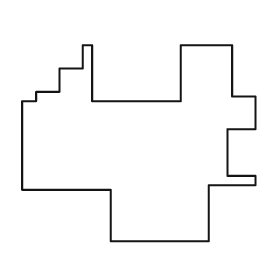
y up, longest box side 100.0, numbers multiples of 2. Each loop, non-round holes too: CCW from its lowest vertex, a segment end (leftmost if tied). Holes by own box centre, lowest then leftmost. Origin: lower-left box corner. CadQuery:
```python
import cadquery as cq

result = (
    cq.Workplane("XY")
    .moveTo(38.0, 0.0)
    .lineTo(80.0, 0.0)
    .lineTo(80.0, 24.0)
    .lineTo(100.0, 24.0)
    .lineTo(100.0, 28.0)
    .lineTo(88.0, 28.0)
    .lineTo(88.0, 48.0)
    .lineTo(100.0, 48.0)
    .lineTo(100.0, 62.0)
    .lineTo(90.0, 62.0)
    .lineTo(90.0, 84.0)
    .lineTo(68.0, 84.0)
    .lineTo(68.0, 60.0)
    .lineTo(30.0, 60.0)
    .lineTo(30.0, 84.0)
    .lineTo(26.0, 84.0)
    .lineTo(26.0, 74.0)
    .lineTo(16.0, 74.0)
    .lineTo(16.0, 64.0)
    .lineTo(6.0, 64.0)
    .lineTo(6.0, 60.0)
    .lineTo(0.0, 60.0)
    .lineTo(0.0, 22.0)
    .lineTo(38.0, 22.0)
    .close()
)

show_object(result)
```